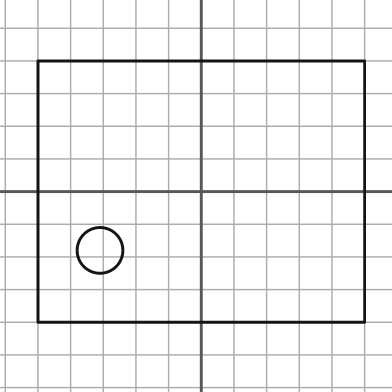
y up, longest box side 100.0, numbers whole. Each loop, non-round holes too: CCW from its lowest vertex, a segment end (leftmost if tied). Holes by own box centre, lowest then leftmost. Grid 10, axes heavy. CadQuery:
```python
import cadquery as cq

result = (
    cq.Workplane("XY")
    .moveTo(-50.0, -40.0)
    .lineTo(50.0, -40.0)
    .lineTo(50.0, 40.0)
    .lineTo(-50.0, 40.0)
    .close()
    .moveTo(-31.0, -18.0)
    .circle(7.0)
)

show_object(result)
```